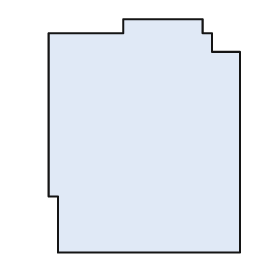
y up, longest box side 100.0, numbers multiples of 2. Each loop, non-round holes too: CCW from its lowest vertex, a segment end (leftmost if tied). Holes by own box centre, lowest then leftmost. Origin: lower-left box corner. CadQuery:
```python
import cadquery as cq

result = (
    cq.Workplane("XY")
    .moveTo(4.0, 0.0)
    .lineTo(82.0, 0.0)
    .lineTo(82.0, 86.0)
    .lineTo(70.0, 86.0)
    .lineTo(70.0, 94.0)
    .lineTo(66.0, 94.0)
    .lineTo(66.0, 100.0)
    .lineTo(32.0, 100.0)
    .lineTo(32.0, 94.0)
    .lineTo(0.0, 94.0)
    .lineTo(0.0, 24.0)
    .lineTo(4.0, 24.0)
    .close()
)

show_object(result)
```